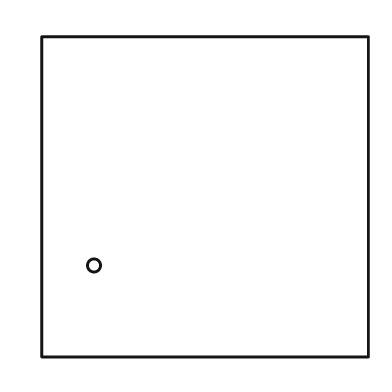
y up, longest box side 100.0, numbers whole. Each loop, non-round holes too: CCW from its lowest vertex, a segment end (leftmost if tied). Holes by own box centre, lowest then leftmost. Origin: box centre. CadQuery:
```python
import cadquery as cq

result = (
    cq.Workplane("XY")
    .moveTo(-50.0, -49.0)
    .lineTo(50.0, -49.0)
    .lineTo(50.0, 49.0)
    .lineTo(-50.0, 49.0)
    .close()
    .moveTo(-34.0, -21.0)
    .circle(2.0)
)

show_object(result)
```